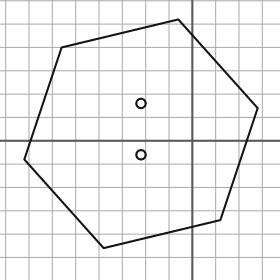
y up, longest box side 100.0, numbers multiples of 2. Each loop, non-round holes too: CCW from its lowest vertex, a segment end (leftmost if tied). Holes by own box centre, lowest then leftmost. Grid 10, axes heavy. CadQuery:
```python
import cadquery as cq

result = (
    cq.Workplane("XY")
    .moveTo(-38.0, -46.0)
    .lineTo(12.0, -34.0)
    .lineTo(28.0, 14.0)
    .lineTo(-6.0, 52.0)
    .lineTo(-56.0, 40.0)
    .lineTo(-72.0, -8.0)
    .close()
    .moveTo(-22.0, -6.0)
    .circle(2.0)
    .moveTo(-22.0, 16.0)
    .circle(2.0)
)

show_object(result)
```